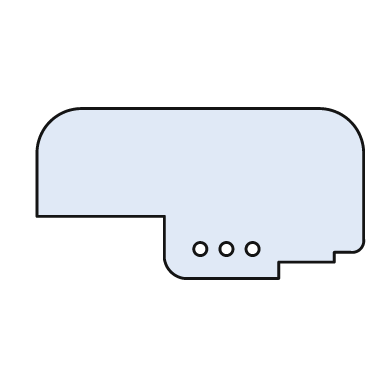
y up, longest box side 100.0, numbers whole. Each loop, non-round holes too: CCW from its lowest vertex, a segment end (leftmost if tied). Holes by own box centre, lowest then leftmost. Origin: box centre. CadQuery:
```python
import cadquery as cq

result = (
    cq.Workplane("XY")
    .moveTo(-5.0, -26.0)
    .lineTo(24.0, -26.0)
    .lineTo(24.0, -21.0)
    .lineTo(41.0, -21.0)
    .lineTo(41.0, -18.0)
    .lineTo(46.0, -18.0)
    .threePointArc((49.0, -17.0), (50.0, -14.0))
    .lineTo(50.0, 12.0)
    .threePointArc((46.0, 22.0), (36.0, 26.0))
    .lineTo(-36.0, 26.0)
    .threePointArc((-46.0, 22.0), (-50.0, 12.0))
    .lineTo(-50.0, -7.0)
    .lineTo(-11.0, -7.0)
    .lineTo(-11.0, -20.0)
    .threePointArc((-9.0, -24.0), (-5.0, -26.0))
    .close()
    .moveTo(0.0, -17.0)
    .circle(2.0)
    .moveTo(8.0, -17.0)
    .circle(2.0)
    .moveTo(16.0, -17.0)
    .circle(2.0)
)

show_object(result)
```